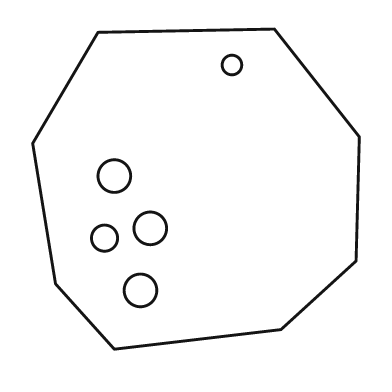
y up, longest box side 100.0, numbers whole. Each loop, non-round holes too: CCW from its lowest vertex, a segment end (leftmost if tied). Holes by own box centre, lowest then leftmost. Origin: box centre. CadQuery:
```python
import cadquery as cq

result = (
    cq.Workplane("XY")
    .moveTo(-25.0, -49.0)
    .lineTo(26.0, -43.0)
    .lineTo(49.0, -22.0)
    .lineTo(50.0, 16.0)
    .lineTo(24.0, 49.0)
    .lineTo(-30.0, 48.0)
    .lineTo(-50.0, 14.0)
    .lineTo(-43.0, -29.0)
    .close()
    .moveTo(-17.0, -31.0)
    .circle(5.0)
    .moveTo(-28.0, -15.0)
    .circle(4.0)
    .moveTo(-14.0, -12.0)
    .circle(5.0)
    .moveTo(-25.0, 4.0)
    .circle(5.0)
    .moveTo(11.0, 38.0)
    .circle(3.0)
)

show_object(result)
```